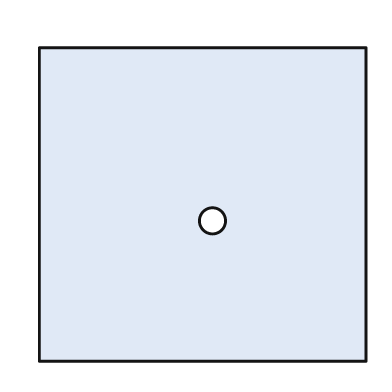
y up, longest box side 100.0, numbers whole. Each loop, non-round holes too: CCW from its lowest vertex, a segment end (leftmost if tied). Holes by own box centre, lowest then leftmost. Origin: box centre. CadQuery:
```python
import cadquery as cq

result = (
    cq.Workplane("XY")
    .moveTo(-50.0, -48.0)
    .lineTo(50.0, -48.0)
    .lineTo(50.0, 48.0)
    .lineTo(-50.0, 48.0)
    .close()
    .moveTo(3.0, -5.0)
    .circle(4.0)
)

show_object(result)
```